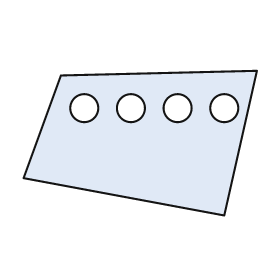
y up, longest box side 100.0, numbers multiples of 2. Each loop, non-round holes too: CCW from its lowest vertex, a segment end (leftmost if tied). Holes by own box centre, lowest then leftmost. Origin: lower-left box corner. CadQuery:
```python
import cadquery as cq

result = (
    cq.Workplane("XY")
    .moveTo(86.0, 0.0)
    .lineTo(100.0, 62.0)
    .lineTo(16.0, 60.0)
    .lineTo(0.0, 16.0)
    .close()
    .moveTo(26.0, 46.0)
    .circle(6.0)
    .moveTo(46.0, 46.0)
    .circle(6.0)
    .moveTo(66.0, 46.0)
    .circle(6.0)
    .moveTo(86.0, 46.0)
    .circle(6.0)
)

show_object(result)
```